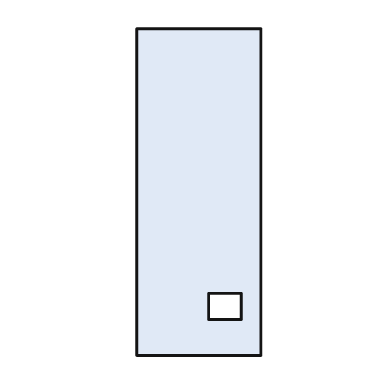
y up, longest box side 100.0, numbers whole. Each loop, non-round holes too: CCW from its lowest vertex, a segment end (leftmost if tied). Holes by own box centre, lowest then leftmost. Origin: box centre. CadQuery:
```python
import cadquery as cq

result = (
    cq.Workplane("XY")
    .moveTo(-19.0, -50.0)
    .lineTo(19.0, -50.0)
    .lineTo(19.0, 50.0)
    .lineTo(-19.0, 50.0)
    .close()
    .moveTo(3.0, -39.0)
    .lineTo(13.0, -39.0)
    .lineTo(13.0, -31.0)
    .lineTo(3.0, -31.0)
    .close()
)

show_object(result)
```